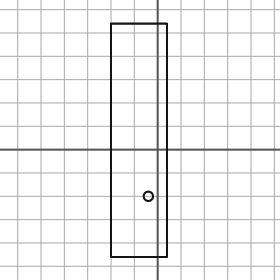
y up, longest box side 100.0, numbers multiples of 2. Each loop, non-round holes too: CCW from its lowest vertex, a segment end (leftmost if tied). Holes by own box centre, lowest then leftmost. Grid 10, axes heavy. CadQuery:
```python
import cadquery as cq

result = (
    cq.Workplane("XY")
    .moveTo(-20.0, -46.0)
    .lineTo(4.0, -46.0)
    .lineTo(4.0, 54.0)
    .lineTo(-20.0, 54.0)
    .close()
    .moveTo(-4.0, -20.0)
    .circle(2.0)
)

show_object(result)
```